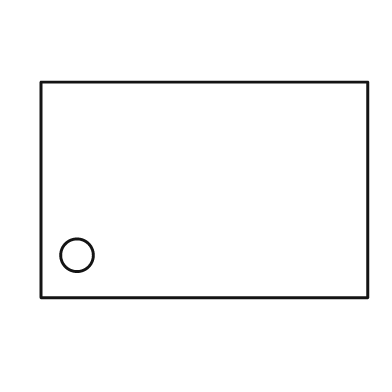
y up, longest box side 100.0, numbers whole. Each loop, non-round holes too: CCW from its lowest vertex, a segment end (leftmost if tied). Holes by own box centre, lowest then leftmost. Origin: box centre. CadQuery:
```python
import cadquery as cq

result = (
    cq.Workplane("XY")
    .moveTo(-50.0, -33.0)
    .lineTo(50.0, -33.0)
    .lineTo(50.0, 33.0)
    .lineTo(-50.0, 33.0)
    .close()
    .moveTo(-39.0, -20.0)
    .circle(5.0)
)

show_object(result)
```